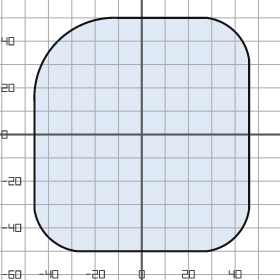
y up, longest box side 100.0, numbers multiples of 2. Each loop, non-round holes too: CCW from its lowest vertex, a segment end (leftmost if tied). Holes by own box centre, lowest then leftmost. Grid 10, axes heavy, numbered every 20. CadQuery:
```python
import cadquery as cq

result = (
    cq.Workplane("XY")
    .moveTo(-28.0, -50.0)
    .lineTo(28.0, -50.0)
    .threePointArc((40.0, -44.0), (46.0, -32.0))
    .lineTo(46.0, 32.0)
    .threePointArc((40.0, 44.0), (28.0, 50.0))
    .lineTo(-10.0, 50.0)
    .threePointArc((-36.0, 40.0), (-46.0, 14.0))
    .lineTo(-46.0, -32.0)
    .threePointArc((-40.0, -44.0), (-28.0, -50.0))
    .close()
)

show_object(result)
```